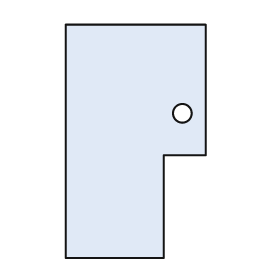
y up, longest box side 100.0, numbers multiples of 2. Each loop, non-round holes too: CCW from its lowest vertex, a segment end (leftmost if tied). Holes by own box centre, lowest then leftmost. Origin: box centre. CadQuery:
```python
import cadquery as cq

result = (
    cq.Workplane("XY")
    .moveTo(-30.0, -50.0)
    .lineTo(12.0, -50.0)
    .lineTo(12.0, -6.0)
    .lineTo(30.0, -6.0)
    .lineTo(30.0, 50.0)
    .lineTo(-30.0, 50.0)
    .close()
    .moveTo(20.0, 12.0)
    .circle(4.0)
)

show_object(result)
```